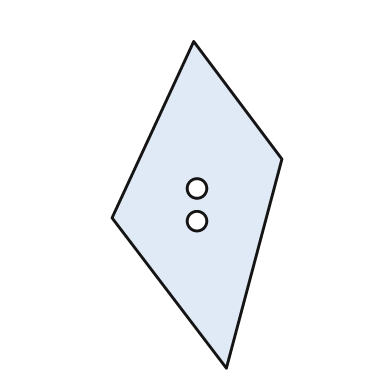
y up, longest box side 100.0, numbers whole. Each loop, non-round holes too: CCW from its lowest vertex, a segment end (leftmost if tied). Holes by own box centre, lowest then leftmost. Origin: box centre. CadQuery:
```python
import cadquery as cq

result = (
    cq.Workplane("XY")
    .moveTo(9.0, -50.0)
    .lineTo(26.0, 14.0)
    .lineTo(-1.0, 50.0)
    .lineTo(-26.0, -4.0)
    .close()
    .moveTo(0.0, -5.0)
    .circle(3.0)
    .moveTo(0.0, 5.0)
    .circle(3.0)
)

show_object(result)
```